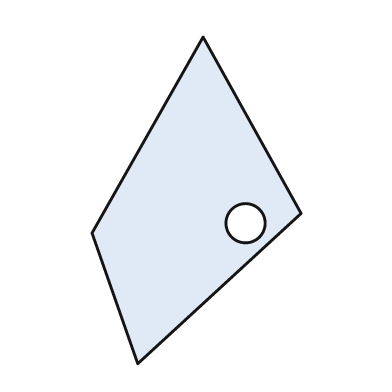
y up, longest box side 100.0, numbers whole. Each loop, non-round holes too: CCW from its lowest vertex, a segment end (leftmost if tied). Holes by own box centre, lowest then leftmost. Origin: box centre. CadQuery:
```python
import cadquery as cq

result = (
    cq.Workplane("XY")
    .moveTo(-18.0, -50.0)
    .lineTo(32.0, -4.0)
    .lineTo(2.0, 50.0)
    .lineTo(-32.0, -10.0)
    .close()
    .moveTo(15.0, -7.0)
    .circle(6.0)
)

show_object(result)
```